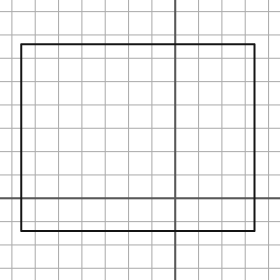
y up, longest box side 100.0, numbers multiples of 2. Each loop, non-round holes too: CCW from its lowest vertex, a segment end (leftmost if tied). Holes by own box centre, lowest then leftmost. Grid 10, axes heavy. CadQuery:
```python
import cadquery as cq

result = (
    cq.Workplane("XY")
    .moveTo(-66.0, -14.0)
    .lineTo(34.0, -14.0)
    .lineTo(34.0, 66.0)
    .lineTo(-66.0, 66.0)
    .close()
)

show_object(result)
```